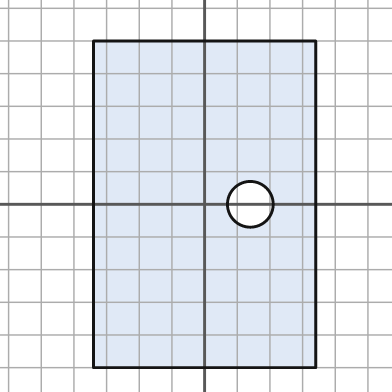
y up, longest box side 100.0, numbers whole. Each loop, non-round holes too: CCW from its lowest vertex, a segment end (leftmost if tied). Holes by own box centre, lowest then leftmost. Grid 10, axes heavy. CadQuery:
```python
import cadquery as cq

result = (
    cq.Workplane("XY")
    .moveTo(-34.0, -50.0)
    .lineTo(34.0, -50.0)
    .lineTo(34.0, 50.0)
    .lineTo(-34.0, 50.0)
    .close()
    .moveTo(14.0, 0.0)
    .circle(7.0)
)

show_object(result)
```